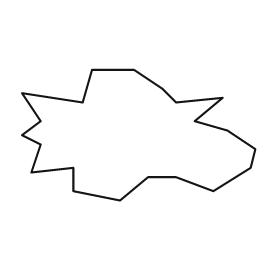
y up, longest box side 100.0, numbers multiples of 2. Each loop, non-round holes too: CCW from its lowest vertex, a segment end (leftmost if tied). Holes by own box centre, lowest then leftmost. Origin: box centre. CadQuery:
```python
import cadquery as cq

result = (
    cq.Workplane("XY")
    .moveTo(-8.0, -28.0)
    .lineTo(4.0, -18.0)
    .lineTo(16.0, -18.0)
    .lineTo(32.0, -24.0)
    .lineTo(48.0, -14.0)
    .lineTo(50.0, -6.0)
    .lineTo(38.0, 2.0)
    .lineTo(24.0, 6.0)
    .lineTo(36.0, 16.0)
    .lineTo(16.0, 14.0)
    .lineTo(10.0, 20.0)
    .lineTo(-2.0, 28.0)
    .lineTo(-20.0, 28.0)
    .lineTo(-24.0, 14.0)
    .lineTo(-50.0, 18.0)
    .lineTo(-42.0, 6.0)
    .lineTo(-50.0, 0.0)
    .lineTo(-42.0, -4.0)
    .lineTo(-46.0, -16.0)
    .lineTo(-28.0, -14.0)
    .lineTo(-28.0, -24.0)
    .close()
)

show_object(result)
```